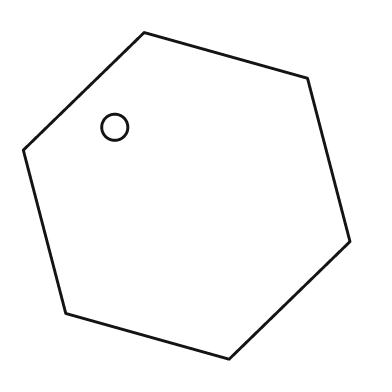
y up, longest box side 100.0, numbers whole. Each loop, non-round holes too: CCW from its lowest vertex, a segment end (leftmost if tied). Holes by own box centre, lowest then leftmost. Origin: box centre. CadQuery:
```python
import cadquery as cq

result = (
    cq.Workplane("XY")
    .moveTo(13.0, -50.0)
    .lineTo(50.0, -14.0)
    .lineTo(37.0, 36.0)
    .lineTo(-13.0, 50.0)
    .lineTo(-50.0, 14.0)
    .lineTo(-37.0, -36.0)
    .close()
    .moveTo(-22.0, 21.0)
    .circle(4.0)
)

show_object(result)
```